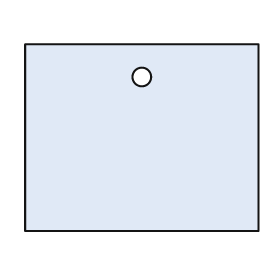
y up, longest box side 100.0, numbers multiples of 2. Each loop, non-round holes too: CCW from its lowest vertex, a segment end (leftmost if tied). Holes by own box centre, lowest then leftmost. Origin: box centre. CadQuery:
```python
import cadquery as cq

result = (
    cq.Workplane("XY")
    .moveTo(-50.0, -40.0)
    .lineTo(50.0, -40.0)
    .lineTo(50.0, 40.0)
    .lineTo(-50.0, 40.0)
    .close()
    .moveTo(0.0, 26.0)
    .circle(4.0)
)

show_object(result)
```